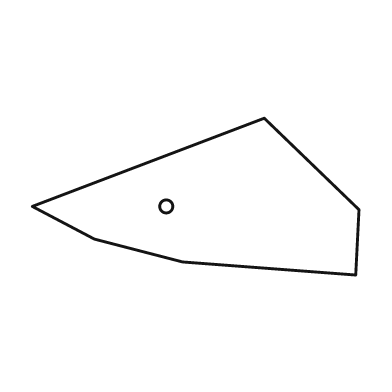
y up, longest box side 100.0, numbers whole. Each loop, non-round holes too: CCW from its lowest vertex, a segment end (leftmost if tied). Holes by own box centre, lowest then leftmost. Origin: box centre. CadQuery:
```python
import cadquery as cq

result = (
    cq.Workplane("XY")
    .moveTo(49.0, -24.0)
    .lineTo(50.0, -4.0)
    .lineTo(21.0, 24.0)
    .lineTo(-50.0, -3.0)
    .lineTo(-31.0, -13.0)
    .lineTo(-4.0, -20.0)
    .close()
    .moveTo(-9.0, -3.0)
    .circle(2.0)
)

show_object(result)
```